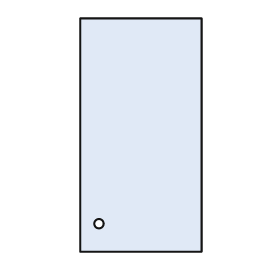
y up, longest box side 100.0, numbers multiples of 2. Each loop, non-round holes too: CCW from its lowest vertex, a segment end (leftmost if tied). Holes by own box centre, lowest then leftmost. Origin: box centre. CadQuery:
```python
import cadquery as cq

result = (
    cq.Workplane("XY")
    .moveTo(-26.0, -50.0)
    .lineTo(26.0, -50.0)
    .lineTo(26.0, 50.0)
    .lineTo(-26.0, 50.0)
    .close()
    .moveTo(-18.0, -38.0)
    .circle(2.0)
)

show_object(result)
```